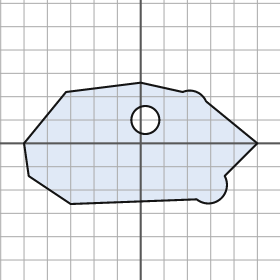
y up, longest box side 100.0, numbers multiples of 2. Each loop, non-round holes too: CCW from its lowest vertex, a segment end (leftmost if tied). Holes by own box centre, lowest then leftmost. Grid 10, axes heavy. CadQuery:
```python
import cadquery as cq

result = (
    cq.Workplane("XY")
    .moveTo(-30.0, -26.0)
    .lineTo(24.0, -24.0)
    .threePointArc((34.0, -24.0), (36.0, -14.0))
    .lineTo(50.0, 0.0)
    .lineTo(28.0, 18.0)
    .threePointArc((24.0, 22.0), (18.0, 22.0))
    .lineTo(0.0, 26.0)
    .lineTo(-32.0, 22.0)
    .lineTo(-50.0, 0.0)
    .lineTo(-48.0, -14.0)
    .close()
    .moveTo(2.0, 10.0)
    .circle(6.0)
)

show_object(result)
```